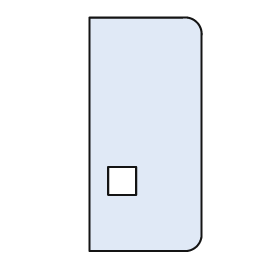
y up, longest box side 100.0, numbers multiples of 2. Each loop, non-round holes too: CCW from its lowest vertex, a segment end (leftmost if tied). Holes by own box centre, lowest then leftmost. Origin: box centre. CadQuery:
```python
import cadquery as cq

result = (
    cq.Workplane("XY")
    .moveTo(-24.0, -50.0)
    .lineTo(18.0, -50.0)
    .threePointArc((22.0, -48.0), (24.0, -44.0))
    .lineTo(24.0, 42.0)
    .threePointArc((22.0, 48.0), (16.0, 50.0))
    .lineTo(-24.0, 50.0)
    .close()
    .moveTo(-16.0, -26.0)
    .lineTo(-4.0, -26.0)
    .lineTo(-4.0, -14.0)
    .lineTo(-16.0, -14.0)
    .close()
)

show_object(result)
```